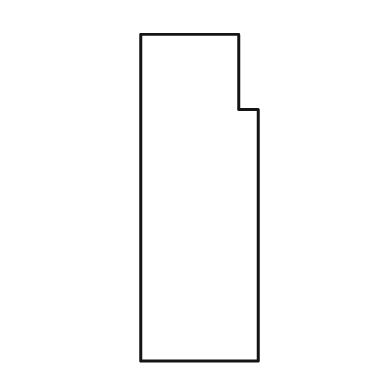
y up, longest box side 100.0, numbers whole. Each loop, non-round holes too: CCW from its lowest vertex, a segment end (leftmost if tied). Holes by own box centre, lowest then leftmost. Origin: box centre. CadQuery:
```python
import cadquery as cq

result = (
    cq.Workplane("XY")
    .moveTo(-18.0, -50.0)
    .lineTo(18.0, -50.0)
    .lineTo(18.0, 27.0)
    .lineTo(12.0, 27.0)
    .lineTo(12.0, 50.0)
    .lineTo(-18.0, 50.0)
    .close()
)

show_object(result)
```